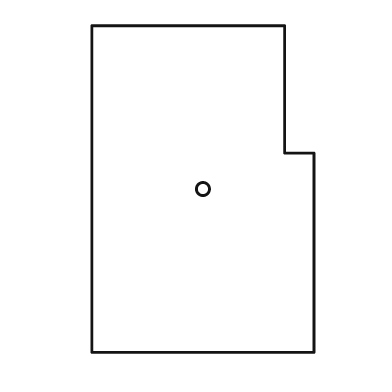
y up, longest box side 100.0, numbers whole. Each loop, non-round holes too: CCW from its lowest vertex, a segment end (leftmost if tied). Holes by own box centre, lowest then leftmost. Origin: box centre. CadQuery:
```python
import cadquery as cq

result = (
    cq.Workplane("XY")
    .moveTo(-34.0, -50.0)
    .lineTo(34.0, -50.0)
    .lineTo(34.0, 11.0)
    .lineTo(25.0, 11.0)
    .lineTo(25.0, 50.0)
    .lineTo(-34.0, 50.0)
    .close()
    .moveTo(0.0, 0.0)
    .circle(2.0)
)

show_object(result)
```